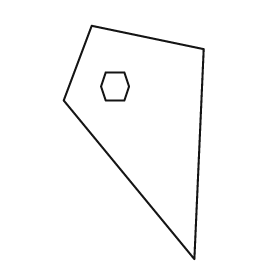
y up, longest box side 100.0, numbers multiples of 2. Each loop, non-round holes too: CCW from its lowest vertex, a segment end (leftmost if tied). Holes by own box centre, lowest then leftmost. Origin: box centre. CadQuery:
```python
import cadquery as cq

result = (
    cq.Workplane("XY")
    .moveTo(26.0, -50.0)
    .lineTo(30.0, 40.0)
    .lineTo(-18.0, 50.0)
    .lineTo(-30.0, 18.0)
    .close()
    .moveTo(-12.0, 18.0)
    .lineTo(-4.0, 18.0)
    .lineTo(-2.0, 24.0)
    .lineTo(-4.0, 30.0)
    .lineTo(-12.0, 30.0)
    .lineTo(-14.0, 24.0)
    .close()
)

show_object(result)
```